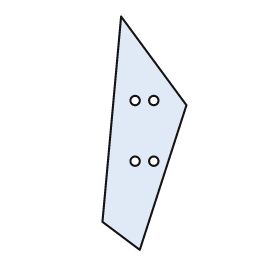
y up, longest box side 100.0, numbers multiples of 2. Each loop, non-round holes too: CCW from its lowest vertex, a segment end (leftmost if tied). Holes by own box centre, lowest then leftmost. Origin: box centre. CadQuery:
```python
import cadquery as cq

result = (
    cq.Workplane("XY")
    .moveTo(-2.0, -50.0)
    .lineTo(18.0, 12.0)
    .lineTo(-10.0, 50.0)
    .lineTo(-18.0, -38.0)
    .close()
    .moveTo(-4.0, -12.0)
    .circle(2.0)
    .moveTo(4.0, -12.0)
    .circle(2.0)
    .moveTo(-4.0, 14.0)
    .circle(2.0)
    .moveTo(4.0, 14.0)
    .circle(2.0)
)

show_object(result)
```